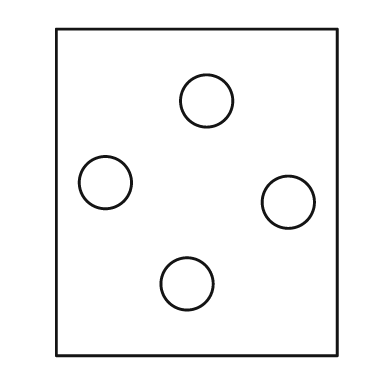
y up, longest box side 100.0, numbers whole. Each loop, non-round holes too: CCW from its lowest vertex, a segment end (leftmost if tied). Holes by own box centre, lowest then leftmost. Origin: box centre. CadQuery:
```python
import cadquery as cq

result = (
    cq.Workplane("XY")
    .moveTo(-43.0, -50.0)
    .lineTo(43.0, -50.0)
    .lineTo(43.0, 50.0)
    .lineTo(-43.0, 50.0)
    .close()
    .moveTo(-3.0, -28.0)
    .circle(8.0)
    .moveTo(28.0, -3.0)
    .circle(8.0)
    .moveTo(-28.0, 3.0)
    .circle(8.0)
    .moveTo(3.0, 28.0)
    .circle(8.0)
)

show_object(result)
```